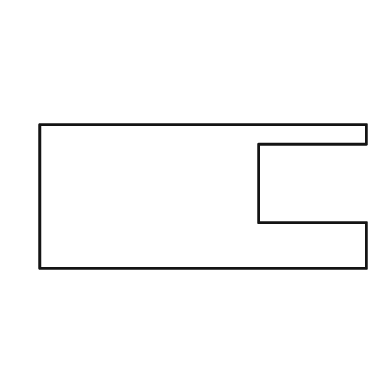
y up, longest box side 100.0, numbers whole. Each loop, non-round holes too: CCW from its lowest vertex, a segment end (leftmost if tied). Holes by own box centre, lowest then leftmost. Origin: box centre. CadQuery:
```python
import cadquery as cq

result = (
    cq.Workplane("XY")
    .moveTo(-50.0, -22.0)
    .lineTo(50.0, -22.0)
    .lineTo(50.0, -8.0)
    .lineTo(17.0, -8.0)
    .lineTo(17.0, 16.0)
    .lineTo(50.0, 16.0)
    .lineTo(50.0, 22.0)
    .lineTo(-50.0, 22.0)
    .close()
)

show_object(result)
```